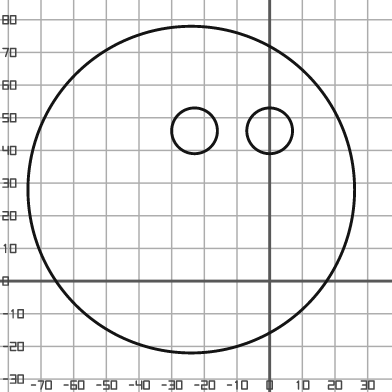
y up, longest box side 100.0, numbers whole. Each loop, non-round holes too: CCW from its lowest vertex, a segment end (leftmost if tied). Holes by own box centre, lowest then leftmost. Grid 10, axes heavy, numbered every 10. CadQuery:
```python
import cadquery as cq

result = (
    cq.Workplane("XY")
    .moveTo(-24.0, 28.0)
    .circle(50.0)
    .moveTo(-23.0, 46.0)
    .circle(7.0)
    .moveTo(0.0, 46.0)
    .circle(7.0)
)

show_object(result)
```